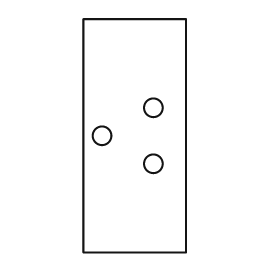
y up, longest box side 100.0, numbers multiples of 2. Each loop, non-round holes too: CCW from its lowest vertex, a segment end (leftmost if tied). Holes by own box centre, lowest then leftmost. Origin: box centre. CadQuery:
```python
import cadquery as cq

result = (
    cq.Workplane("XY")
    .moveTo(-22.0, -50.0)
    .lineTo(22.0, -50.0)
    .lineTo(22.0, 50.0)
    .lineTo(-22.0, 50.0)
    .close()
    .moveTo(8.0, -12.0)
    .circle(4.0)
    .moveTo(-14.0, 0.0)
    .circle(4.0)
    .moveTo(8.0, 12.0)
    .circle(4.0)
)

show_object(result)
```